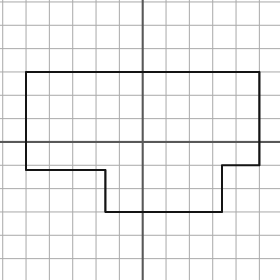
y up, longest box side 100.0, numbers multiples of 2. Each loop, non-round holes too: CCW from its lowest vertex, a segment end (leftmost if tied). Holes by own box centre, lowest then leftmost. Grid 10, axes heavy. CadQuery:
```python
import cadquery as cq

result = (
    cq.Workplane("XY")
    .moveTo(-16.0, -30.0)
    .lineTo(34.0, -30.0)
    .lineTo(34.0, -10.0)
    .lineTo(50.0, -10.0)
    .lineTo(50.0, 30.0)
    .lineTo(-50.0, 30.0)
    .lineTo(-50.0, -12.0)
    .lineTo(-16.0, -12.0)
    .close()
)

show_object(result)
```